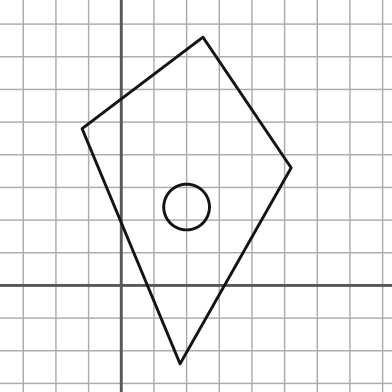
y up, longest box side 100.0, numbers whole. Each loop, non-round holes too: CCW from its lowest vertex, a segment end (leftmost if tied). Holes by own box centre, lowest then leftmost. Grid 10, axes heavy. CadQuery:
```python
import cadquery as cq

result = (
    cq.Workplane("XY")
    .moveTo(18.0, -24.0)
    .lineTo(52.0, 36.0)
    .lineTo(25.0, 76.0)
    .lineTo(-12.0, 48.0)
    .close()
    .moveTo(20.0, 24.0)
    .circle(7.0)
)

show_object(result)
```